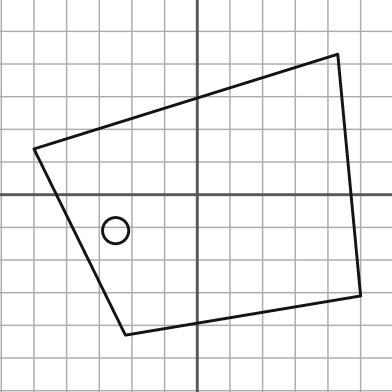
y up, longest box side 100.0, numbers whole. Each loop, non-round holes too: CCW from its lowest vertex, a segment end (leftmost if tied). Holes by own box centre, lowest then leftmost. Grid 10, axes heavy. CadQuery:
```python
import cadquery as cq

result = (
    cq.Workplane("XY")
    .moveTo(-22.0, -43.0)
    .lineTo(50.0, -31.0)
    .lineTo(43.0, 43.0)
    .lineTo(-50.0, 14.0)
    .close()
    .moveTo(-25.0, -11.0)
    .circle(4.0)
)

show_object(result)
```